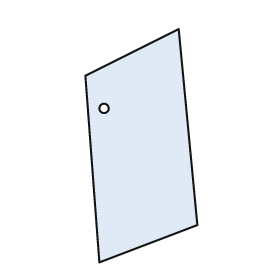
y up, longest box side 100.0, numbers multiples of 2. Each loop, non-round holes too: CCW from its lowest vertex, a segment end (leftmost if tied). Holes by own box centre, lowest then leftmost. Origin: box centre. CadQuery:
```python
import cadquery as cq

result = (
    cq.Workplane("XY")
    .moveTo(-18.0, -50.0)
    .lineTo(24.0, -34.0)
    .lineTo(16.0, 50.0)
    .lineTo(-24.0, 30.0)
    .close()
    .moveTo(-16.0, 16.0)
    .circle(2.0)
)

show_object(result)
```